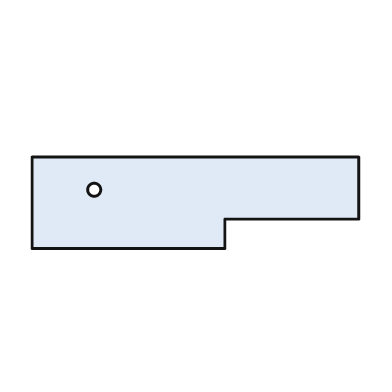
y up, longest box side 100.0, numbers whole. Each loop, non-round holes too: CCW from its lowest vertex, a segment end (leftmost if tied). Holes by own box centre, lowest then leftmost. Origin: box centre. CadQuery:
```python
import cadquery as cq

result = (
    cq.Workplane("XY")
    .moveTo(-50.0, -14.0)
    .lineTo(9.0, -14.0)
    .lineTo(9.0, -5.0)
    .lineTo(50.0, -5.0)
    .lineTo(50.0, 14.0)
    .lineTo(-50.0, 14.0)
    .close()
    .moveTo(-31.0, 4.0)
    .circle(2.0)
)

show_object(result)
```